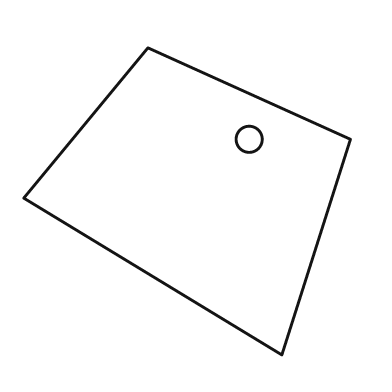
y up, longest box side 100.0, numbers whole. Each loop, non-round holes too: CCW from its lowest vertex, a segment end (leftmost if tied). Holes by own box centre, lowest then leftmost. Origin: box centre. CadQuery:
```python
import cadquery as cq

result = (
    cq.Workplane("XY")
    .moveTo(29.0, -47.0)
    .lineTo(50.0, 19.0)
    .lineTo(-12.0, 47.0)
    .lineTo(-50.0, 1.0)
    .close()
    .moveTo(19.0, 19.0)
    .circle(4.0)
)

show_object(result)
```